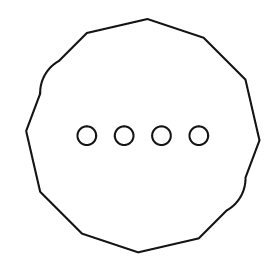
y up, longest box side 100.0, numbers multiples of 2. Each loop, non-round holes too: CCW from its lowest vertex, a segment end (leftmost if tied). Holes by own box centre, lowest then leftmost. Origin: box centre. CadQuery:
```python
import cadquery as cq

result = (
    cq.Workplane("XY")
    .moveTo(-2.0, -50.0)
    .lineTo(24.0, -44.0)
    .lineTo(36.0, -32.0)
    .threePointArc((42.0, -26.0), (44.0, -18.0))
    .lineTo(50.0, -2.0)
    .lineTo(44.0, 24.0)
    .lineTo(26.0, 42.0)
    .lineTo(2.0, 50.0)
    .lineTo(-24.0, 44.0)
    .lineTo(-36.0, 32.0)
    .threePointArc((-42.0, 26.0), (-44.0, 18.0))
    .lineTo(-50.0, 2.0)
    .lineTo(-44.0, -24.0)
    .lineTo(-26.0, -42.0)
    .close()
    .moveTo(-24.0, 0.0)
    .circle(4.0)
    .moveTo(-8.0, 0.0)
    .circle(4.0)
    .moveTo(8.0, 0.0)
    .circle(4.0)
    .moveTo(24.0, 0.0)
    .circle(4.0)
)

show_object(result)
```